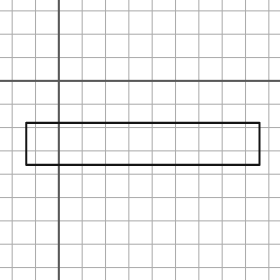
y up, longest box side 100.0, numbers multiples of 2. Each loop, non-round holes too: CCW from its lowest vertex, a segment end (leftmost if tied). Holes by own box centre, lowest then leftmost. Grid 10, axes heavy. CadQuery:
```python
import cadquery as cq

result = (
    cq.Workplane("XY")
    .moveTo(-14.0, -36.0)
    .lineTo(86.0, -36.0)
    .lineTo(86.0, -18.0)
    .lineTo(-14.0, -18.0)
    .close()
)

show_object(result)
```